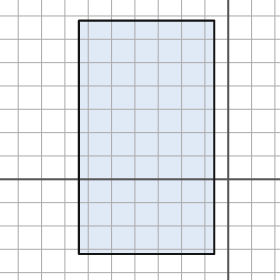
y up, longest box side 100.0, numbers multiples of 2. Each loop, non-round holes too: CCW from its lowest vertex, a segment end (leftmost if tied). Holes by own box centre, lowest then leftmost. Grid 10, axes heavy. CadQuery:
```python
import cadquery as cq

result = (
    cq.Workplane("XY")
    .moveTo(-64.0, -32.0)
    .lineTo(-6.0, -32.0)
    .lineTo(-6.0, 68.0)
    .lineTo(-64.0, 68.0)
    .close()
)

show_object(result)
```